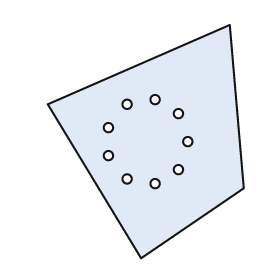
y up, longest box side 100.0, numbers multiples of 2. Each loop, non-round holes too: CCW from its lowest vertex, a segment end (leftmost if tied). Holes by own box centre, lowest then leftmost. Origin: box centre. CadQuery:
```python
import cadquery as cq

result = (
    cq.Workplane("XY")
    .moveTo(-2.0, -50.0)
    .lineTo(42.0, -20.0)
    .lineTo(36.0, 50.0)
    .lineTo(-42.0, 16.0)
    .close()
    .moveTo(4.0, -18.0)
    .circle(2.0)
    .moveTo(-8.0, -16.0)
    .circle(2.0)
    .moveTo(14.0, -12.0)
    .circle(2.0)
    .moveTo(-16.0, -6.0)
    .circle(2.0)
    .moveTo(18.0, 0.0)
    .circle(2.0)
    .moveTo(-16.0, 6.0)
    .circle(2.0)
    .moveTo(14.0, 12.0)
    .circle(2.0)
    .moveTo(-8.0, 16.0)
    .circle(2.0)
    .moveTo(4.0, 18.0)
    .circle(2.0)
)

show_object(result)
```